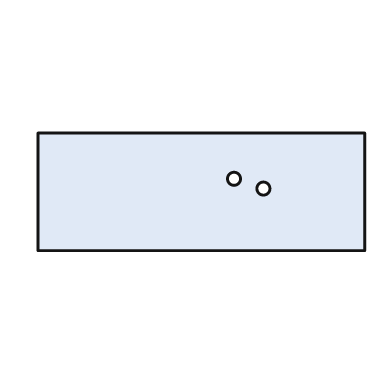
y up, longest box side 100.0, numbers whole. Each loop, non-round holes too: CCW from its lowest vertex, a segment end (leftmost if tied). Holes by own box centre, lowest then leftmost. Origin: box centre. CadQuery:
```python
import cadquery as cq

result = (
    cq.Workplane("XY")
    .moveTo(-50.0, -18.0)
    .lineTo(50.0, -18.0)
    .lineTo(50.0, 18.0)
    .lineTo(-50.0, 18.0)
    .close()
    .moveTo(19.0, 1.0)
    .circle(2.0)
    .moveTo(10.0, 4.0)
    .circle(2.0)
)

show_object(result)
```